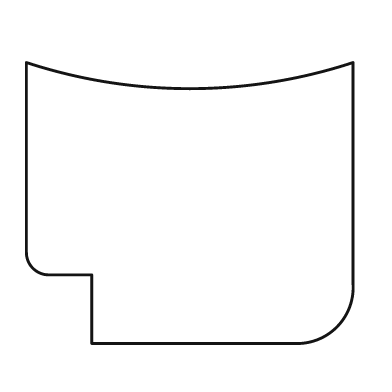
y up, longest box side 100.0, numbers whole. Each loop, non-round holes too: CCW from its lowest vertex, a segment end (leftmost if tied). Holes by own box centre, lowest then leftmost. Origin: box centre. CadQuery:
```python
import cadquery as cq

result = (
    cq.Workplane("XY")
    .moveTo(-30.0, -43.0)
    .lineTo(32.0, -43.0)
    .threePointArc((45.0, -38.0), (50.0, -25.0))
    .lineTo(50.0, 43.0)
    .threePointArc((0.0, 35.0), (-50.0, 43.0))
    .lineTo(-50.0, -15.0)
    .threePointArc((-48.0, -20.0), (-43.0, -22.0))
    .lineTo(-30.0, -22.0)
    .close()
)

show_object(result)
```